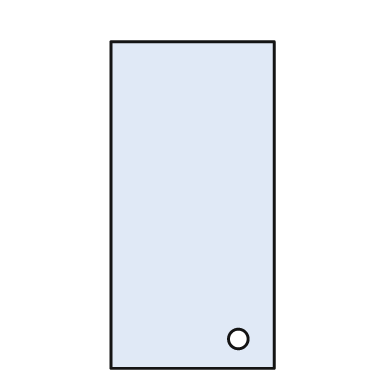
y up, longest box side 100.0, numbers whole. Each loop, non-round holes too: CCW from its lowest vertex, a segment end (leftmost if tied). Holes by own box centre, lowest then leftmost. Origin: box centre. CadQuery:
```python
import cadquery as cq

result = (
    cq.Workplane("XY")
    .moveTo(-25.0, -50.0)
    .lineTo(25.0, -50.0)
    .lineTo(25.0, 50.0)
    .lineTo(-25.0, 50.0)
    .close()
    .moveTo(14.0, -41.0)
    .circle(3.0)
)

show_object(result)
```